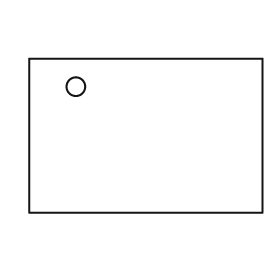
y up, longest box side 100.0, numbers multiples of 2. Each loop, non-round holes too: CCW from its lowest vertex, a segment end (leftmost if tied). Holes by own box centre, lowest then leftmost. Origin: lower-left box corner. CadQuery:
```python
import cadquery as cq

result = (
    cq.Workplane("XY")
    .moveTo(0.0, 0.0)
    .lineTo(100.0, 0.0)
    .lineTo(100.0, 66.0)
    .lineTo(0.0, 66.0)
    .close()
    .moveTo(20.0, 54.0)
    .circle(4.0)
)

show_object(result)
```